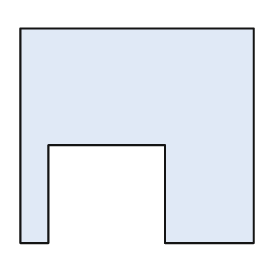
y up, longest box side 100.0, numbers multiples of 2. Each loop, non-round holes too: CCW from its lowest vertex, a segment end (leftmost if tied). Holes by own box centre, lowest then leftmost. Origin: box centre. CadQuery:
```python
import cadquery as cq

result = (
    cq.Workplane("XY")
    .moveTo(-50.0, -46.0)
    .lineTo(-38.0, -46.0)
    .lineTo(-38.0, -4.0)
    .lineTo(12.0, -4.0)
    .lineTo(12.0, -46.0)
    .lineTo(50.0, -46.0)
    .lineTo(50.0, 46.0)
    .lineTo(-50.0, 46.0)
    .close()
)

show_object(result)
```